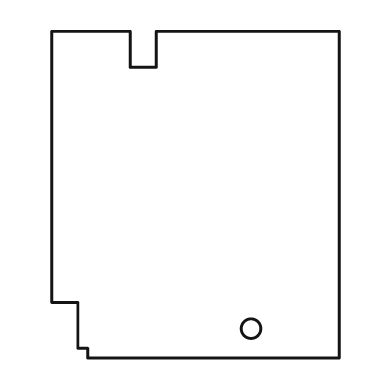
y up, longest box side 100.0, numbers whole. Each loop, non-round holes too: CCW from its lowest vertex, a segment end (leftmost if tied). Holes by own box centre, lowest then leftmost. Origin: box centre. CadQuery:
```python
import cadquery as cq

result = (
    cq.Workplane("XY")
    .moveTo(-33.0, -50.0)
    .lineTo(44.0, -50.0)
    .lineTo(44.0, 50.0)
    .lineTo(-12.0, 50.0)
    .lineTo(-12.0, 39.0)
    .lineTo(-20.0, 39.0)
    .lineTo(-20.0, 50.0)
    .lineTo(-44.0, 50.0)
    .lineTo(-44.0, -33.0)
    .lineTo(-36.0, -33.0)
    .lineTo(-36.0, -47.0)
    .lineTo(-33.0, -47.0)
    .close()
    .moveTo(17.0, -41.0)
    .circle(3.0)
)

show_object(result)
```